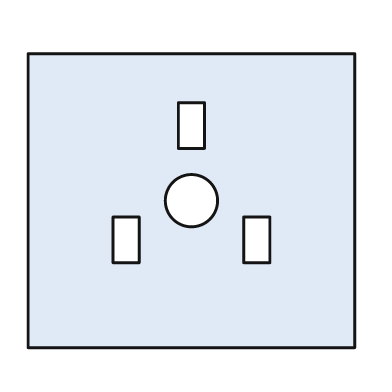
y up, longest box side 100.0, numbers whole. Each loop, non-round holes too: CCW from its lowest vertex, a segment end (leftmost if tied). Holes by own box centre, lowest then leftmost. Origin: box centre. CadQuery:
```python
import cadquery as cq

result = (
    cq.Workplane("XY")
    .moveTo(-50.0, -45.0)
    .lineTo(50.0, -45.0)
    .lineTo(50.0, 45.0)
    .lineTo(-50.0, 45.0)
    .close()
    .moveTo(-24.0, -19.0)
    .lineTo(-16.0, -19.0)
    .lineTo(-16.0, -5.0)
    .lineTo(-24.0, -5.0)
    .close()
    .moveTo(16.0, -19.0)
    .lineTo(24.0, -19.0)
    .lineTo(24.0, -5.0)
    .lineTo(16.0, -5.0)
    .close()
    .moveTo(0.0, 0.0)
    .circle(8.0)
    .moveTo(-4.0, 16.0)
    .lineTo(4.0, 16.0)
    .lineTo(4.0, 30.0)
    .lineTo(-4.0, 30.0)
    .close()
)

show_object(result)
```